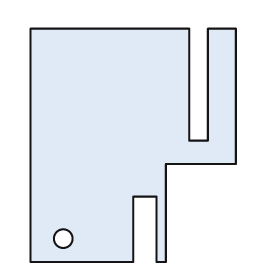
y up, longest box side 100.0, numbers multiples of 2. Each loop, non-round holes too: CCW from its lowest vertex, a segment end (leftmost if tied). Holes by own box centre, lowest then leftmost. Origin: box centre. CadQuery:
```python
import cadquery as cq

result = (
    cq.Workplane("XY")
    .moveTo(-44.0, -50.0)
    .lineTo(0.0, -50.0)
    .lineTo(0.0, -22.0)
    .lineTo(10.0, -22.0)
    .lineTo(10.0, -50.0)
    .lineTo(14.0, -50.0)
    .lineTo(14.0, -8.0)
    .lineTo(44.0, -8.0)
    .lineTo(44.0, 50.0)
    .lineTo(32.0, 50.0)
    .lineTo(32.0, 2.0)
    .lineTo(24.0, 2.0)
    .lineTo(24.0, 50.0)
    .lineTo(-44.0, 50.0)
    .close()
    .moveTo(-30.0, -40.0)
    .circle(4.0)
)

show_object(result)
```